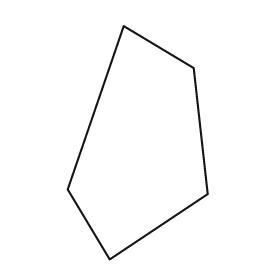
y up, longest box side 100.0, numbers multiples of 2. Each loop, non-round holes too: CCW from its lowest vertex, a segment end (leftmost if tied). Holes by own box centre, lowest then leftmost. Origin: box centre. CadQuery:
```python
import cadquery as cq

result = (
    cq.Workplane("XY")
    .moveTo(-12.0, -50.0)
    .lineTo(30.0, -22.0)
    .lineTo(24.0, 32.0)
    .lineTo(-6.0, 50.0)
    .lineTo(-30.0, -20.0)
    .close()
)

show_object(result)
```